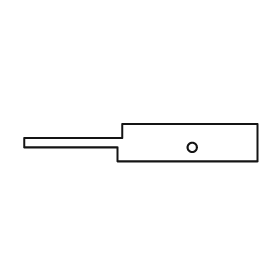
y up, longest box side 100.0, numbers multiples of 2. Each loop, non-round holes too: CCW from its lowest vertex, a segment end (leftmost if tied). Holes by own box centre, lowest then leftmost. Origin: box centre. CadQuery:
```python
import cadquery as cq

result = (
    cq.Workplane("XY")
    .moveTo(-10.0, -8.0)
    .lineTo(50.0, -8.0)
    .lineTo(50.0, 8.0)
    .lineTo(-8.0, 8.0)
    .lineTo(-8.0, 2.0)
    .lineTo(-50.0, 2.0)
    .lineTo(-50.0, -2.0)
    .lineTo(-10.0, -2.0)
    .close()
    .moveTo(22.0, -2.0)
    .circle(2.0)
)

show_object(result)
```